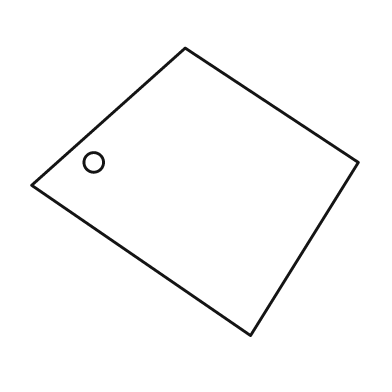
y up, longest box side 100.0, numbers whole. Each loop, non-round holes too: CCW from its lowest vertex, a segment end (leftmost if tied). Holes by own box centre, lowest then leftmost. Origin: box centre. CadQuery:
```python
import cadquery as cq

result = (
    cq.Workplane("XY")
    .moveTo(17.0, -44.0)
    .lineTo(50.0, 9.0)
    .lineTo(-3.0, 44.0)
    .lineTo(-50.0, 2.0)
    .close()
    .moveTo(-31.0, 9.0)
    .circle(3.0)
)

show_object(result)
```